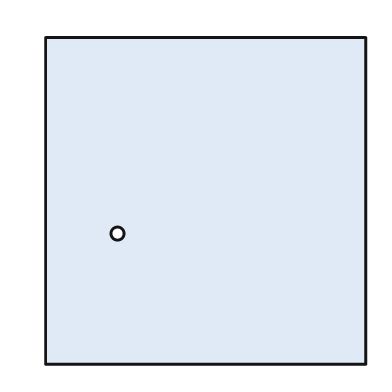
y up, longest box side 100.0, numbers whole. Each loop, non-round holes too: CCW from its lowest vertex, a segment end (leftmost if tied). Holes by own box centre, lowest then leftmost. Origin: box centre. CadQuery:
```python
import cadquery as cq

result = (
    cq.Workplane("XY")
    .moveTo(-49.0, -50.0)
    .lineTo(49.0, -50.0)
    .lineTo(49.0, 50.0)
    .lineTo(-49.0, 50.0)
    .close()
    .moveTo(-27.0, -10.0)
    .circle(2.0)
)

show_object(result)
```